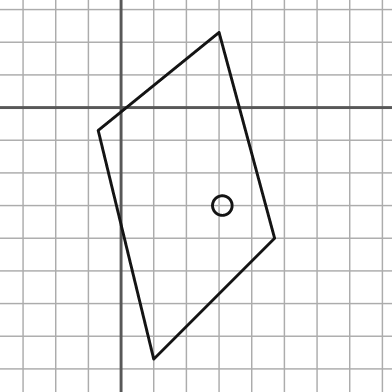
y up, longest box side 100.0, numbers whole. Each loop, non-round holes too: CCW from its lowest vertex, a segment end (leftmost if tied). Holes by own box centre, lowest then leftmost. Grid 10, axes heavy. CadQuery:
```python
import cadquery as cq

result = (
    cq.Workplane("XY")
    .moveTo(10.0, -77.0)
    .lineTo(47.0, -40.0)
    .lineTo(30.0, 23.0)
    .lineTo(-7.0, -7.0)
    .close()
    .moveTo(31.0, -30.0)
    .circle(3.0)
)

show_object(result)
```